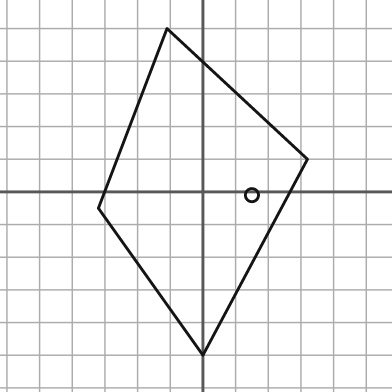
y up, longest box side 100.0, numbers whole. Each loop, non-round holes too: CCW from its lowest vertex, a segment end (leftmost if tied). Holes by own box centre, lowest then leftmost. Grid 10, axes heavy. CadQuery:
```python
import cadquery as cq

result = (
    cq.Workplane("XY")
    .moveTo(0.0, -50.0)
    .lineTo(32.0, 10.0)
    .lineTo(-11.0, 50.0)
    .lineTo(-32.0, -5.0)
    .close()
    .moveTo(15.0, -1.0)
    .circle(2.0)
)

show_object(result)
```